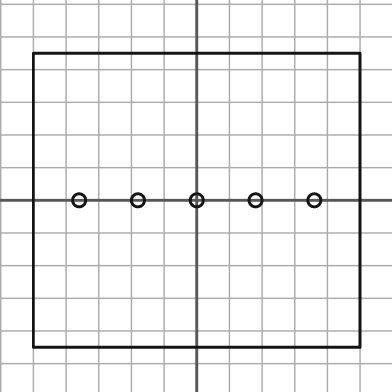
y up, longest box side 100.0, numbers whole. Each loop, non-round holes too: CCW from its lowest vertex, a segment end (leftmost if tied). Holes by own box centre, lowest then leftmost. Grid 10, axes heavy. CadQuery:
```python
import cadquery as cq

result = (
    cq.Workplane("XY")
    .moveTo(-50.0, -45.0)
    .lineTo(50.0, -45.0)
    .lineTo(50.0, 45.0)
    .lineTo(-50.0, 45.0)
    .close()
    .moveTo(-36.0, 0.0)
    .circle(2.0)
    .moveTo(-18.0, 0.0)
    .circle(2.0)
    .moveTo(0.0, 0.0)
    .circle(2.0)
    .moveTo(18.0, 0.0)
    .circle(2.0)
    .moveTo(36.0, 0.0)
    .circle(2.0)
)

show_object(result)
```